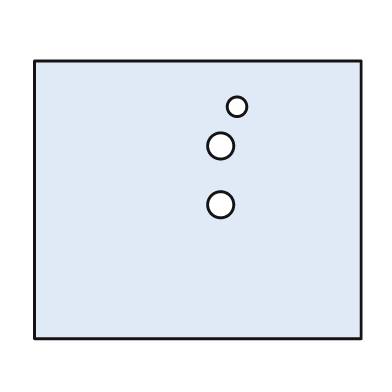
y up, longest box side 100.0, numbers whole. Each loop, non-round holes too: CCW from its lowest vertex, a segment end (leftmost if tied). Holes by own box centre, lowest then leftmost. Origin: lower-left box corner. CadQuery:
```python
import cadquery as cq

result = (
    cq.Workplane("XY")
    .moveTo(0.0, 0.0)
    .lineTo(100.0, 0.0)
    .lineTo(100.0, 85.0)
    .lineTo(0.0, 85.0)
    .close()
    .moveTo(57.0, 41.0)
    .circle(4.0)
    .moveTo(57.0, 59.0)
    .circle(4.0)
    .moveTo(62.0, 71.0)
    .circle(3.0)
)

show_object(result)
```